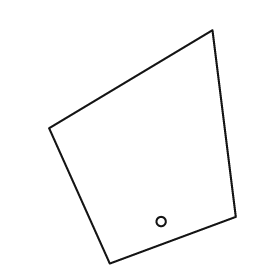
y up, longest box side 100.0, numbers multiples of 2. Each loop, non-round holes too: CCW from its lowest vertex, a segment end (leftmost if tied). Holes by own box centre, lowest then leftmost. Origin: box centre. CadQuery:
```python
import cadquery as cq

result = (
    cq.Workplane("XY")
    .moveTo(-14.0, -50.0)
    .lineTo(40.0, -30.0)
    .lineTo(30.0, 50.0)
    .lineTo(-40.0, 8.0)
    .close()
    .moveTo(8.0, -32.0)
    .circle(2.0)
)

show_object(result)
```